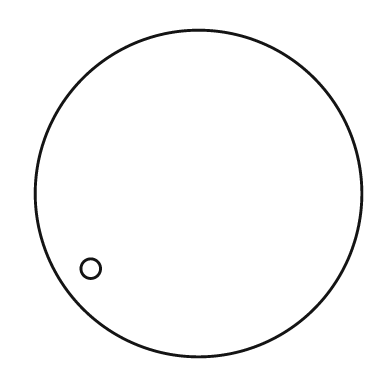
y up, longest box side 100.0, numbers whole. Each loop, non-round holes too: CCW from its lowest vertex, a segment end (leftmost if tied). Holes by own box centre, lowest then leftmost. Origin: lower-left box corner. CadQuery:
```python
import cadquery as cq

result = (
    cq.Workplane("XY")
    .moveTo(50.0, 50.0)
    .circle(50.0)
    .moveTo(17.0, 27.0)
    .circle(3.0)
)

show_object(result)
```